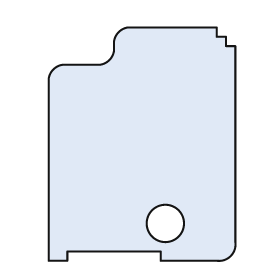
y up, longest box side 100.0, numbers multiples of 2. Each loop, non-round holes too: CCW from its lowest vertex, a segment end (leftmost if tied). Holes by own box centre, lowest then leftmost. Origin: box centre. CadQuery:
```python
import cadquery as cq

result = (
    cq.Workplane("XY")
    .moveTo(-40.0, -50.0)
    .lineTo(-32.0, -50.0)
    .lineTo(-32.0, -46.0)
    .lineTo(8.0, -46.0)
    .lineTo(8.0, -50.0)
    .lineTo(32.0, -50.0)
    .threePointArc((38.0, -48.0), (40.0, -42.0))
    .lineTo(40.0, 42.0)
    .lineTo(36.0, 42.0)
    .lineTo(36.0, 46.0)
    .lineTo(32.0, 46.0)
    .lineTo(32.0, 50.0)
    .lineTo(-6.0, 50.0)
    .threePointArc((-10.0, 48.0), (-12.0, 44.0))
    .lineTo(-12.0, 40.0)
    .threePointArc((-14.0, 36.0), (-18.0, 34.0))
    .lineTo(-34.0, 34.0)
    .threePointArc((-38.0, 32.0), (-40.0, 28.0))
    .close()
    .moveTo(10.0, -34.0)
    .circle(8.0)
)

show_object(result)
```